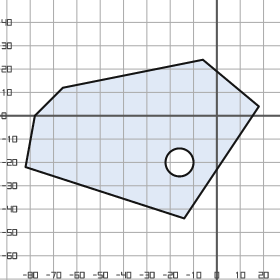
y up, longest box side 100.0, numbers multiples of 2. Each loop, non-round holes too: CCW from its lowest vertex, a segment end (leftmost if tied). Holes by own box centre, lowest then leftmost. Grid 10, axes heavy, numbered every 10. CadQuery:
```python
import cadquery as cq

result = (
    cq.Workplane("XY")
    .moveTo(-14.0, -44.0)
    .lineTo(18.0, 4.0)
    .lineTo(-6.0, 24.0)
    .lineTo(-66.0, 12.0)
    .lineTo(-78.0, 0.0)
    .lineTo(-82.0, -22.0)
    .close()
    .moveTo(-16.0, -20.0)
    .circle(6.0)
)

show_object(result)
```